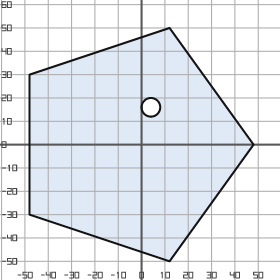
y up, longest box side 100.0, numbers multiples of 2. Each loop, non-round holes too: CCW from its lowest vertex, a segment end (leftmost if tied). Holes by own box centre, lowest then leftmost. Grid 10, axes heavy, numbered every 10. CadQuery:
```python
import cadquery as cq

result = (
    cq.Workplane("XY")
    .moveTo(12.0, -50.0)
    .lineTo(48.0, 0.0)
    .lineTo(12.0, 50.0)
    .lineTo(-48.0, 30.0)
    .lineTo(-48.0, -30.0)
    .close()
    .moveTo(4.0, 16.0)
    .circle(4.0)
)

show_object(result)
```